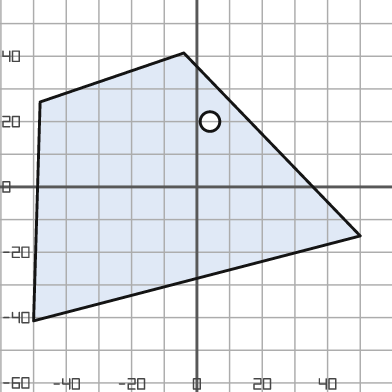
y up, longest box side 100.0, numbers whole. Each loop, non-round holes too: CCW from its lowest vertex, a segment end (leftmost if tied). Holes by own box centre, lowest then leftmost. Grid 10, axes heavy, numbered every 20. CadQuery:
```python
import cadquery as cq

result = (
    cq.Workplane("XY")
    .moveTo(-50.0, -41.0)
    .lineTo(50.0, -15.0)
    .lineTo(-4.0, 41.0)
    .lineTo(-48.0, 26.0)
    .close()
    .moveTo(4.0, 20.0)
    .circle(3.0)
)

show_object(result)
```